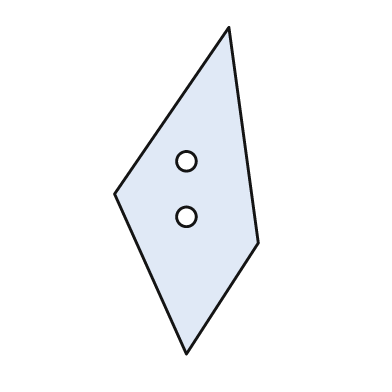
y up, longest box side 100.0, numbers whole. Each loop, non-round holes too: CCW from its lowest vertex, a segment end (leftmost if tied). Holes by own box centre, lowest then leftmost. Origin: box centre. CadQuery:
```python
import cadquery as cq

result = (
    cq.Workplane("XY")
    .moveTo(0.0, -50.0)
    .lineTo(22.0, -16.0)
    .lineTo(13.0, 50.0)
    .lineTo(-22.0, -1.0)
    .close()
    .moveTo(0.0, -8.0)
    .circle(3.0)
    .moveTo(0.0, 9.0)
    .circle(3.0)
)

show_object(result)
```